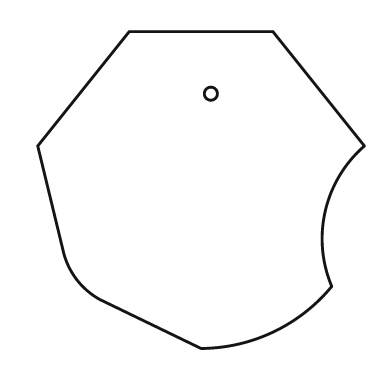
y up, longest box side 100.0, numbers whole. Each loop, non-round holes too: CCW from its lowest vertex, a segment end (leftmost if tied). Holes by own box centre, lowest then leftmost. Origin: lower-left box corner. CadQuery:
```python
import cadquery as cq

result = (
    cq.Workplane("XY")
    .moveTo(50.0, 0.0)
    .threePointArc((72.0, 5.0), (90.0, 19.0))
    .threePointArc((88.0, 42.0), (100.0, 62.0))
    .lineTo(72.0, 97.0)
    .lineTo(28.0, 97.0)
    .lineTo(0.0, 62.0)
    .lineTo(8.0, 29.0)
    .threePointArc((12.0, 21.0), (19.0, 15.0))
    .close()
    .moveTo(53.0, 78.0)
    .circle(2.0)
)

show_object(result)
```